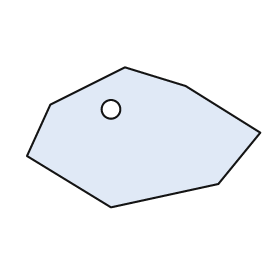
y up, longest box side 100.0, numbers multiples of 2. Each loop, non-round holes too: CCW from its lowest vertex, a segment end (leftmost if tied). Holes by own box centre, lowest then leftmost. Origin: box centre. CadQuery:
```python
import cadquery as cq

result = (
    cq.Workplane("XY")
    .moveTo(-14.0, -30.0)
    .lineTo(32.0, -20.0)
    .lineTo(50.0, 2.0)
    .lineTo(18.0, 22.0)
    .lineTo(-8.0, 30.0)
    .lineTo(-40.0, 14.0)
    .lineTo(-50.0, -8.0)
    .close()
    .moveTo(-14.0, 12.0)
    .circle(4.0)
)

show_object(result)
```